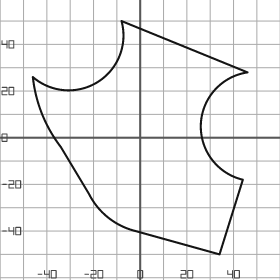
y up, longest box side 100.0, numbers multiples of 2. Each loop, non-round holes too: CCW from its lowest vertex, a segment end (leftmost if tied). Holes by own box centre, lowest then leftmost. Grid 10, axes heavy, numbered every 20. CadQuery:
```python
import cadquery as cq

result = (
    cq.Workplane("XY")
    .moveTo(34.0, -50.0)
    .lineTo(44.0, -18.0)
    .threePointArc((26.0, 6.0), (46.0, 28.0))
    .lineTo(-8.0, 50.0)
    .threePointArc((-18.0, 24.0), (-46.0, 26.0))
    .threePointArc((-42.0, 10.0), (-34.0, -4.0))
    .lineTo(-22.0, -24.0)
    .threePointArc((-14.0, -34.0), (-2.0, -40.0))
    .close()
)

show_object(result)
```